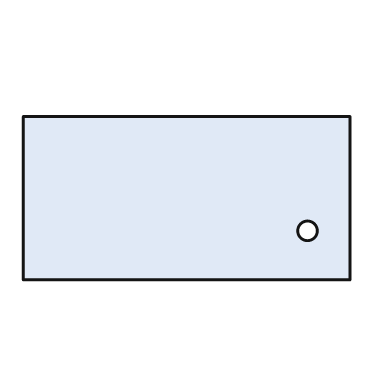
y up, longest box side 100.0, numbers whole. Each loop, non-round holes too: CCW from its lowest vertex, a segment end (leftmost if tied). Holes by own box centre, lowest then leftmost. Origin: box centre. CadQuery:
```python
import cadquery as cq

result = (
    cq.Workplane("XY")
    .moveTo(-50.0, -25.0)
    .lineTo(50.0, -25.0)
    .lineTo(50.0, 25.0)
    .lineTo(-50.0, 25.0)
    .close()
    .moveTo(37.0, -10.0)
    .circle(3.0)
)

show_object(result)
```